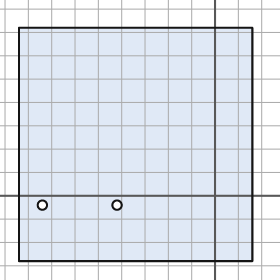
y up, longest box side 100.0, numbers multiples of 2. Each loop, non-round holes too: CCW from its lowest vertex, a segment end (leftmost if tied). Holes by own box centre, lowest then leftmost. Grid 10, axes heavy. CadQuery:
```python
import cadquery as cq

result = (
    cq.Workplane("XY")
    .moveTo(-84.0, -28.0)
    .lineTo(16.0, -28.0)
    .lineTo(16.0, 72.0)
    .lineTo(-84.0, 72.0)
    .close()
    .moveTo(-74.0, -4.0)
    .circle(2.0)
    .moveTo(-42.0, -4.0)
    .circle(2.0)
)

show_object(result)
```